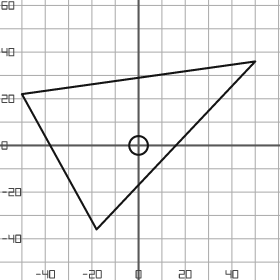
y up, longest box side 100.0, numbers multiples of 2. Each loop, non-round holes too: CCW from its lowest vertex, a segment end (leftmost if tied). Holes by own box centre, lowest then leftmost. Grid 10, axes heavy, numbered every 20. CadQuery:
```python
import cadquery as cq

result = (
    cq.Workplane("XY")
    .moveTo(-18.0, -36.0)
    .lineTo(50.0, 36.0)
    .lineTo(-50.0, 22.0)
    .close()
    .moveTo(0.0, 0.0)
    .circle(4.0)
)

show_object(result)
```